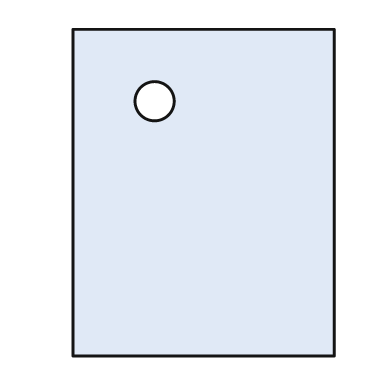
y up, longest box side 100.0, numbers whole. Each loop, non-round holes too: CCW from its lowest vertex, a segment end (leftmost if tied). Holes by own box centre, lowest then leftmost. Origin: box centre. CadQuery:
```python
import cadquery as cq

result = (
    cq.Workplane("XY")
    .moveTo(-40.0, -50.0)
    .lineTo(40.0, -50.0)
    .lineTo(40.0, 50.0)
    .lineTo(-40.0, 50.0)
    .close()
    .moveTo(-15.0, 28.0)
    .circle(6.0)
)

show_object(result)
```